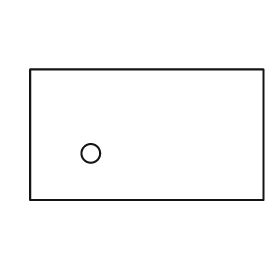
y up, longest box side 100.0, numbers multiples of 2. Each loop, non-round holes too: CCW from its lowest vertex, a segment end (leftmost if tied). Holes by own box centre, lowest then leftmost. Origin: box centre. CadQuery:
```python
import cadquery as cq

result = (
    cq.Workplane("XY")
    .moveTo(-50.0, -28.0)
    .lineTo(50.0, -28.0)
    .lineTo(50.0, 28.0)
    .lineTo(-50.0, 28.0)
    .close()
    .moveTo(-24.0, -8.0)
    .circle(4.0)
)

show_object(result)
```